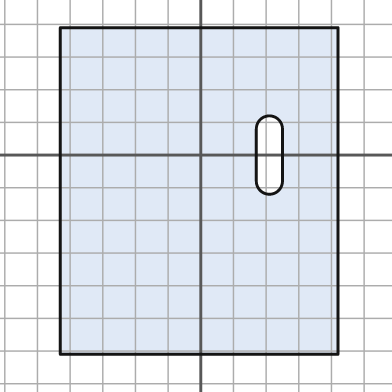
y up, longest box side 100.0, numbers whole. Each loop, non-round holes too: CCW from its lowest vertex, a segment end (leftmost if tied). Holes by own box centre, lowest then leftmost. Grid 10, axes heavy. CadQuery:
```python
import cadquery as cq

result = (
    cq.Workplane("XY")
    .moveTo(-43.0, -61.0)
    .lineTo(42.0, -61.0)
    .lineTo(42.0, 39.0)
    .lineTo(-43.0, 39.0)
    .close()
    .moveTo(17.0, -8.0)
    .threePointArc((21.0, -12.0), (25.0, -8.0))
    .lineTo(25.0, 8.0)
    .threePointArc((21.0, 12.0), (17.0, 8.0))
    .close()
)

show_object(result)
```